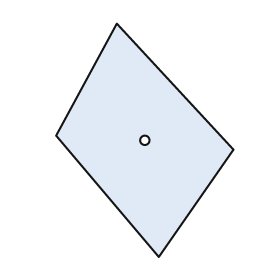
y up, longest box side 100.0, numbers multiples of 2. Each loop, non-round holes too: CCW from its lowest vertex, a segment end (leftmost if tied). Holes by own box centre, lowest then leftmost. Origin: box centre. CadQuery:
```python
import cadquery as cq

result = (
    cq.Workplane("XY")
    .moveTo(6.0, -50.0)
    .lineTo(38.0, -4.0)
    .lineTo(-12.0, 50.0)
    .lineTo(-38.0, 2.0)
    .close()
    .moveTo(0.0, 0.0)
    .circle(2.0)
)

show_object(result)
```